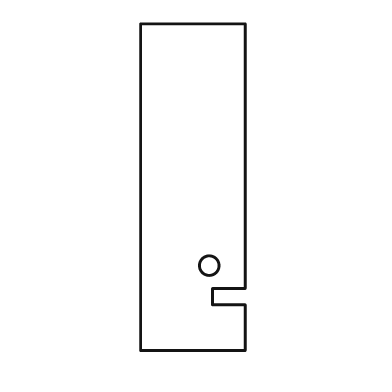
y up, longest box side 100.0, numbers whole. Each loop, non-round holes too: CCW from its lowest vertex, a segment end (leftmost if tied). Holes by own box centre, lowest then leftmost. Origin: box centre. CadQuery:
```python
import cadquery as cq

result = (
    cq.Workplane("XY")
    .moveTo(-16.0, -50.0)
    .lineTo(16.0, -50.0)
    .lineTo(16.0, -36.0)
    .lineTo(6.0, -36.0)
    .lineTo(6.0, -31.0)
    .lineTo(16.0, -31.0)
    .lineTo(16.0, 50.0)
    .lineTo(-16.0, 50.0)
    .close()
    .moveTo(5.0, -24.0)
    .circle(3.0)
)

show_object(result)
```